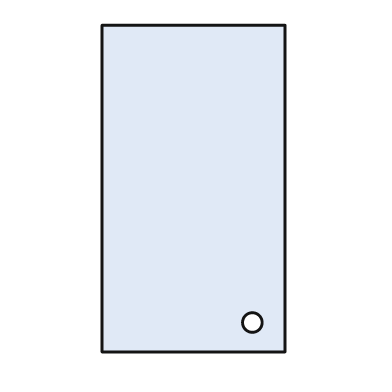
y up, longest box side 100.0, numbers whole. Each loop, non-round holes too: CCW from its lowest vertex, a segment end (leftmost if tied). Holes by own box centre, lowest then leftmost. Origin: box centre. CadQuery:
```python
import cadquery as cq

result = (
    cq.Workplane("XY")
    .moveTo(-28.0, -50.0)
    .lineTo(28.0, -50.0)
    .lineTo(28.0, 50.0)
    .lineTo(-28.0, 50.0)
    .close()
    .moveTo(18.0, -41.0)
    .circle(3.0)
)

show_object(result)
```